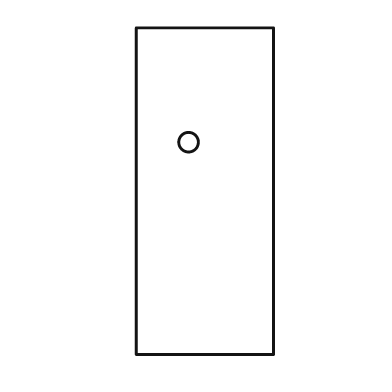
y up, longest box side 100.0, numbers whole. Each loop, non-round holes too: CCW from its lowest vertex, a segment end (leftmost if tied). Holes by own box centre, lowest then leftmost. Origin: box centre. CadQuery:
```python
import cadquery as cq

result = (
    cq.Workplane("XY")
    .moveTo(-21.0, -50.0)
    .lineTo(21.0, -50.0)
    .lineTo(21.0, 50.0)
    .lineTo(-21.0, 50.0)
    .close()
    .moveTo(-5.0, 15.0)
    .circle(3.0)
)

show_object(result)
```